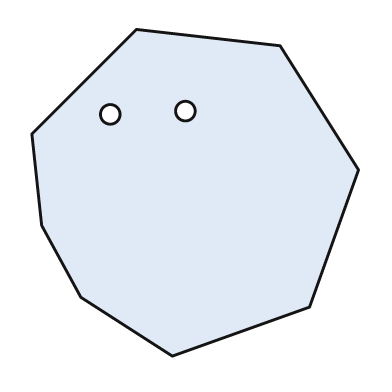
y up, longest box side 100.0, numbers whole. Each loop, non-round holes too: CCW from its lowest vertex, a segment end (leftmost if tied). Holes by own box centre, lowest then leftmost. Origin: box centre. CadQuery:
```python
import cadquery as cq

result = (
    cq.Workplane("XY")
    .moveTo(-7.0, -50.0)
    .lineTo(35.0, -35.0)
    .lineTo(50.0, 7.0)
    .lineTo(26.0, 45.0)
    .lineTo(-18.0, 50.0)
    .lineTo(-50.0, 18.0)
    .lineTo(-47.0, -10.0)
    .lineTo(-35.0, -32.0)
    .close()
    .moveTo(-26.0, 24.0)
    .circle(3.0)
    .moveTo(-3.0, 25.0)
    .circle(3.0)
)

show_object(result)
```